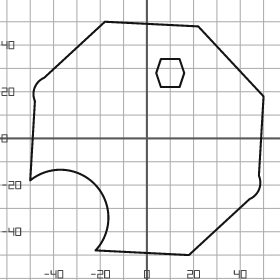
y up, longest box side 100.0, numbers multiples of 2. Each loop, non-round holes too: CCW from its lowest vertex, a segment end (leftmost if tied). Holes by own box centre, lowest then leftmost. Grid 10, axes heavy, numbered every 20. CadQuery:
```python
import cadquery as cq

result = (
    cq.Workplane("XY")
    .moveTo(18.0, -50.0)
    .lineTo(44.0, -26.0)
    .threePointArc((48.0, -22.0), (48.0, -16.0))
    .lineTo(50.0, 18.0)
    .lineTo(22.0, 48.0)
    .lineTo(-18.0, 50.0)
    .lineTo(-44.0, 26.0)
    .threePointArc((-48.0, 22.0), (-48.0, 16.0))
    .lineTo(-50.0, -18.0)
    .threePointArc((-22.0, -20.0), (-22.0, -48.0))
    .close()
    .moveTo(6.0, 22.0)
    .lineTo(14.0, 22.0)
    .lineTo(16.0, 28.0)
    .lineTo(14.0, 34.0)
    .lineTo(6.0, 34.0)
    .lineTo(4.0, 28.0)
    .close()
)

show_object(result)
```